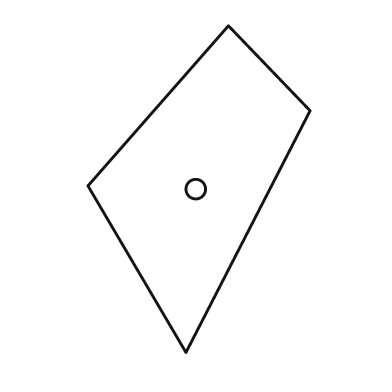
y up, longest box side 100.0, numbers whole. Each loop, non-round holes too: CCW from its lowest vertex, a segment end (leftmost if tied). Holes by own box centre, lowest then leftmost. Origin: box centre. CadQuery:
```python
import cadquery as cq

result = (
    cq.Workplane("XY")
    .moveTo(-4.0, -50.0)
    .lineTo(34.0, 24.0)
    .lineTo(9.0, 50.0)
    .lineTo(-34.0, 1.0)
    .close()
    .moveTo(-1.0, 0.0)
    .circle(3.0)
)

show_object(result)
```